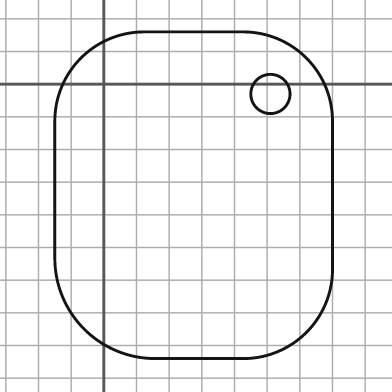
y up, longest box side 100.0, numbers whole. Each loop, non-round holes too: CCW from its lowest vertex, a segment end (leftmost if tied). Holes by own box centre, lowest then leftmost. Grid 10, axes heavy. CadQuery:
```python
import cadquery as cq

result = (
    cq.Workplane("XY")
    .moveTo(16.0, -84.0)
    .lineTo(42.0, -84.0)
    .threePointArc((62.0, -76.0), (70.0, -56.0))
    .lineTo(70.0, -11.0)
    .threePointArc((62.0, 8.0), (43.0, 16.0))
    .lineTo(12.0, 16.0)
    .threePointArc((-7.0, 8.0), (-15.0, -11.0))
    .lineTo(-15.0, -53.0)
    .threePointArc((-6.0, -75.0), (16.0, -84.0))
    .close()
    .moveTo(51.0, -3.0)
    .circle(6.0)
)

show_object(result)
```